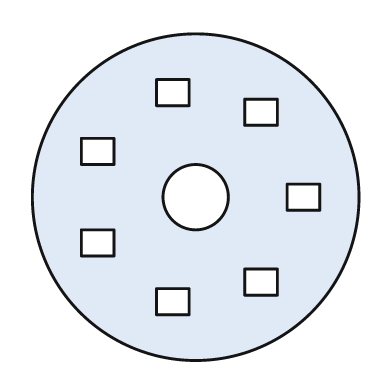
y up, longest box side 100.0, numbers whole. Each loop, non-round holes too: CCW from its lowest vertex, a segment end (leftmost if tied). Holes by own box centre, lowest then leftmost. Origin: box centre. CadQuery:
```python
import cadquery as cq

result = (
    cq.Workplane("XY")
    .moveTo(0.0, 0.0)
    .circle(50.0)
    .moveTo(-12.0, -36.0)
    .lineTo(-2.0, -36.0)
    .lineTo(-2.0, -28.0)
    .lineTo(-12.0, -28.0)
    .close()
    .moveTo(15.0, -30.0)
    .lineTo(25.0, -30.0)
    .lineTo(25.0, -22.0)
    .lineTo(15.0, -22.0)
    .close()
    .moveTo(-35.0, -18.0)
    .lineTo(-25.0, -18.0)
    .lineTo(-25.0, -10.0)
    .lineTo(-35.0, -10.0)
    .close()
    .moveTo(0.0, 0.0)
    .circle(10.0)
    .moveTo(28.0, -4.0)
    .lineTo(38.0, -4.0)
    .lineTo(38.0, 4.0)
    .lineTo(28.0, 4.0)
    .close()
    .moveTo(-35.0, 10.0)
    .lineTo(-25.0, 10.0)
    .lineTo(-25.0, 18.0)
    .lineTo(-35.0, 18.0)
    .close()
    .moveTo(15.0, 22.0)
    .lineTo(25.0, 22.0)
    .lineTo(25.0, 30.0)
    .lineTo(15.0, 30.0)
    .close()
    .moveTo(-12.0, 28.0)
    .lineTo(-2.0, 28.0)
    .lineTo(-2.0, 36.0)
    .lineTo(-12.0, 36.0)
    .close()
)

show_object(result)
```